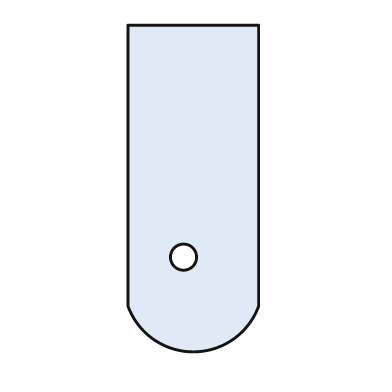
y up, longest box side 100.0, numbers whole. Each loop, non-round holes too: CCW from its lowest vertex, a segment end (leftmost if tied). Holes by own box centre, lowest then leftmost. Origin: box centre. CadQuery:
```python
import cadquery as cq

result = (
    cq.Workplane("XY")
    .moveTo(-20.0, -36.0)
    .threePointArc((0.0, -50.0), (20.0, -36.0))
    .lineTo(20.0, 50.0)
    .lineTo(-20.0, 50.0)
    .close()
    .moveTo(-3.0, -21.0)
    .circle(4.0)
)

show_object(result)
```